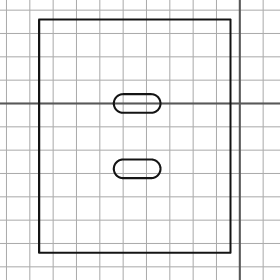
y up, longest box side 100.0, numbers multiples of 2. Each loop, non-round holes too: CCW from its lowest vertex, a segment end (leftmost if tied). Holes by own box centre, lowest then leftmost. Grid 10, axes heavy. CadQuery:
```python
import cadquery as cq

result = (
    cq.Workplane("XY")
    .moveTo(-86.0, -64.0)
    .lineTo(-4.0, -64.0)
    .lineTo(-4.0, 36.0)
    .lineTo(-86.0, 36.0)
    .close()
    .moveTo(-50.0, -32.0)
    .lineTo(-38.0, -32.0)
    .threePointArc((-34.0, -28.0), (-38.0, -24.0))
    .lineTo(-50.0, -24.0)
    .threePointArc((-54.0, -28.0), (-50.0, -32.0))
    .close()
    .moveTo(-50.0, -4.0)
    .lineTo(-38.0, -4.0)
    .threePointArc((-34.0, 0.0), (-38.0, 4.0))
    .lineTo(-50.0, 4.0)
    .threePointArc((-54.0, 0.0), (-50.0, -4.0))
    .close()
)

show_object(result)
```